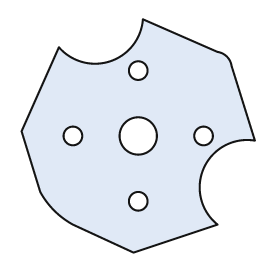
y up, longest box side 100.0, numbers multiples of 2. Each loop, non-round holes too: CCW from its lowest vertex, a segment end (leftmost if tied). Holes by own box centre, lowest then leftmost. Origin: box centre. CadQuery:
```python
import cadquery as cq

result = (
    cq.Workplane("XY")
    .moveTo(-2.0, -50.0)
    .lineTo(34.0, -38.0)
    .threePointArc((28.0, -14.0), (50.0, -2.0))
    .lineTo(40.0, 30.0)
    .threePointArc((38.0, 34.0), (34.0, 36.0))
    .lineTo(2.0, 50.0)
    .threePointArc((-12.0, 32.0), (-34.0, 38.0))
    .lineTo(-50.0, 2.0)
    .lineTo(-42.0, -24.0)
    .threePointArc((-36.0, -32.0), (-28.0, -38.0))
    .close()
    .moveTo(0.0, -28.0)
    .circle(4.0)
    .moveTo(-28.0, 0.0)
    .circle(4.0)
    .moveTo(0.0, 0.0)
    .circle(8.0)
    .moveTo(28.0, 0.0)
    .circle(4.0)
    .moveTo(0.0, 28.0)
    .circle(4.0)
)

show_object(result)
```